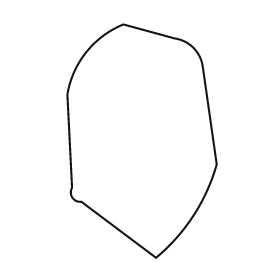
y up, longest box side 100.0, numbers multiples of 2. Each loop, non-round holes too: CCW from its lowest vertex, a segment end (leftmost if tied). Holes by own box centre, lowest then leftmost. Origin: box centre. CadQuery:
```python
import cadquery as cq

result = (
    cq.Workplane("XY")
    .moveTo(6.0, -50.0)
    .threePointArc((22.0, -32.0), (32.0, -10.0))
    .lineTo(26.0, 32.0)
    .threePointArc((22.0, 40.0), (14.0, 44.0))
    .lineTo(-8.0, 50.0)
    .threePointArc((-24.0, 38.0), (-32.0, 20.0))
    .lineTo(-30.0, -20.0)
    .threePointArc((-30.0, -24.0), (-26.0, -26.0))
    .close()
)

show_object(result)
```